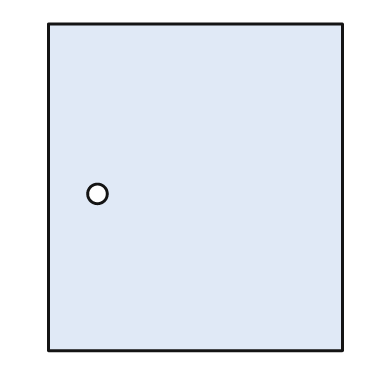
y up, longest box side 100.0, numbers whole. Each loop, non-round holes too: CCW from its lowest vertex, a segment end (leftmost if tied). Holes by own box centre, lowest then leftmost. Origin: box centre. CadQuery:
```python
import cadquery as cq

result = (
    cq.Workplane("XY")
    .moveTo(-45.0, -50.0)
    .lineTo(45.0, -50.0)
    .lineTo(45.0, 50.0)
    .lineTo(-45.0, 50.0)
    .close()
    .moveTo(-30.0, -2.0)
    .circle(3.0)
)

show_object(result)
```